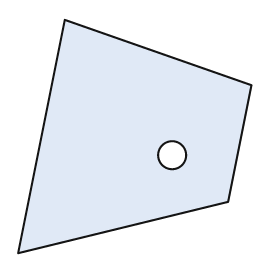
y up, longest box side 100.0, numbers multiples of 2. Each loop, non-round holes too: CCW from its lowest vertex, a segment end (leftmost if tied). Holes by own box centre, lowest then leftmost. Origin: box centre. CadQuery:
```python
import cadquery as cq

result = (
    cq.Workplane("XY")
    .moveTo(-50.0, -50.0)
    .lineTo(40.0, -28.0)
    .lineTo(50.0, 22.0)
    .lineTo(-30.0, 50.0)
    .close()
    .moveTo(16.0, -8.0)
    .circle(6.0)
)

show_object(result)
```